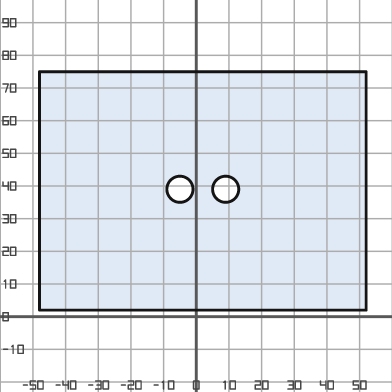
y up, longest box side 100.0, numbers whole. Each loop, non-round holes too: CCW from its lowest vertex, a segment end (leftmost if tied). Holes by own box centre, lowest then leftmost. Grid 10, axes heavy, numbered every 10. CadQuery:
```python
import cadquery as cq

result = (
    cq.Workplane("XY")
    .moveTo(-48.0, 2.0)
    .lineTo(52.0, 2.0)
    .lineTo(52.0, 75.0)
    .lineTo(-48.0, 75.0)
    .close()
    .moveTo(-5.0, 39.0)
    .circle(4.0)
    .moveTo(9.0, 39.0)
    .circle(4.0)
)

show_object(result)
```